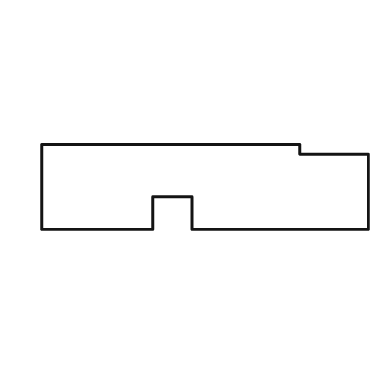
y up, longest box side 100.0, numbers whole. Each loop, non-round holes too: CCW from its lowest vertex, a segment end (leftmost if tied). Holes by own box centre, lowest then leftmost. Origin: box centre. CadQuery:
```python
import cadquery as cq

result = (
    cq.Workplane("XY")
    .moveTo(-50.0, -13.0)
    .lineTo(-16.0, -13.0)
    .lineTo(-16.0, -3.0)
    .lineTo(-4.0, -3.0)
    .lineTo(-4.0, -13.0)
    .lineTo(50.0, -13.0)
    .lineTo(50.0, 10.0)
    .lineTo(29.0, 10.0)
    .lineTo(29.0, 13.0)
    .lineTo(-50.0, 13.0)
    .close()
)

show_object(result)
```